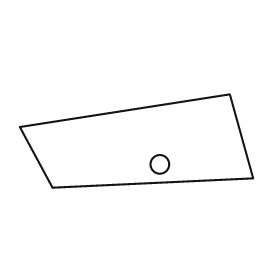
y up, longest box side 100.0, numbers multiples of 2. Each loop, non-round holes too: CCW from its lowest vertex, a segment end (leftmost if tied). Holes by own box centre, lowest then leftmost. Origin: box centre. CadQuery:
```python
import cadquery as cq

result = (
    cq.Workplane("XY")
    .moveTo(-36.0, -20.0)
    .lineTo(50.0, -16.0)
    .lineTo(40.0, 20.0)
    .lineTo(-50.0, 6.0)
    .close()
    .moveTo(10.0, -10.0)
    .circle(4.0)
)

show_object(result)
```